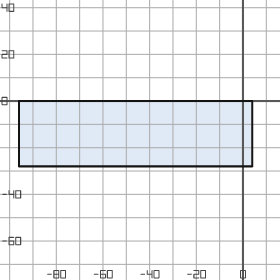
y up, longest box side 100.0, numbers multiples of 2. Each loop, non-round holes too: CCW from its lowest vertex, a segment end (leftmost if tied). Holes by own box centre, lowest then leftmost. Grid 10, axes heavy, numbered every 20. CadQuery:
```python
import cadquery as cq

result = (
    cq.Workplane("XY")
    .moveTo(-96.0, -28.0)
    .lineTo(4.0, -28.0)
    .lineTo(4.0, 0.0)
    .lineTo(-96.0, 0.0)
    .close()
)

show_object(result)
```